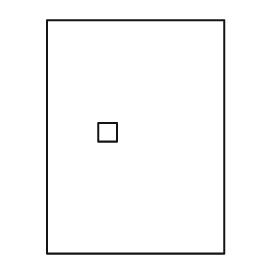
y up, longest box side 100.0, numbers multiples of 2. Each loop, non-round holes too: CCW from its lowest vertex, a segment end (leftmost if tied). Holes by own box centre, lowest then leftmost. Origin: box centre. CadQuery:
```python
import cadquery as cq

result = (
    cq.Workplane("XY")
    .moveTo(-38.0, -50.0)
    .lineTo(38.0, -50.0)
    .lineTo(38.0, 50.0)
    .lineTo(-38.0, 50.0)
    .close()
    .moveTo(-16.0, -2.0)
    .lineTo(-8.0, -2.0)
    .lineTo(-8.0, 6.0)
    .lineTo(-16.0, 6.0)
    .close()
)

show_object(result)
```